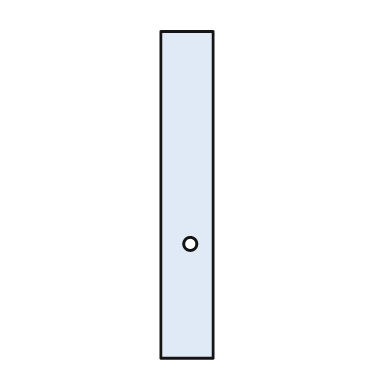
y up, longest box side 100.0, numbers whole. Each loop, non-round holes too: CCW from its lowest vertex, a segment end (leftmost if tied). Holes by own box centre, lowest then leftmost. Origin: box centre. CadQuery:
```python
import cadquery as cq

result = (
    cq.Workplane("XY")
    .moveTo(-8.0, -50.0)
    .lineTo(8.0, -50.0)
    .lineTo(8.0, 50.0)
    .lineTo(-8.0, 50.0)
    .close()
    .moveTo(1.0, -15.0)
    .circle(2.0)
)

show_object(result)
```